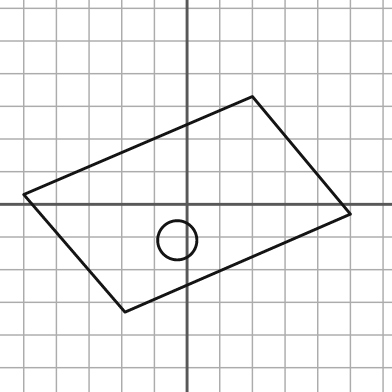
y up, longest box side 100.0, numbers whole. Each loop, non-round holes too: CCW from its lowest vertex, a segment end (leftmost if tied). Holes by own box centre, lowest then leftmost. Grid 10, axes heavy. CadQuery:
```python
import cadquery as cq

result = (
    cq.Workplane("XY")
    .moveTo(-19.0, -33.0)
    .lineTo(50.0, -3.0)
    .lineTo(20.0, 33.0)
    .lineTo(-50.0, 3.0)
    .close()
    .moveTo(-3.0, -11.0)
    .circle(6.0)
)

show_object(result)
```